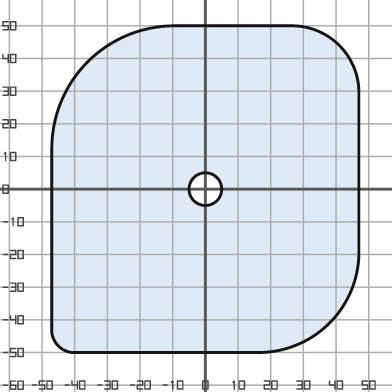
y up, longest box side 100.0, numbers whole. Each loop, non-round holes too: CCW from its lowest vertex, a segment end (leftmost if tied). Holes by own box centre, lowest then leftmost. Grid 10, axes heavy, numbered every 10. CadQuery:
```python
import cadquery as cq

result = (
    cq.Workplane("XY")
    .moveTo(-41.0, -50.0)
    .lineTo(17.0, -50.0)
    .threePointArc((38.0, -41.0), (47.0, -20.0))
    .lineTo(47.0, 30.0)
    .threePointArc((41.0, 44.0), (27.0, 50.0))
    .lineTo(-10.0, 50.0)
    .threePointArc((-36.0, 39.0), (-47.0, 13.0))
    .lineTo(-47.0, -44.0)
    .threePointArc((-45.0, -48.0), (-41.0, -50.0))
    .close()
    .moveTo(0.0, 0.0)
    .circle(5.0)
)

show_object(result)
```